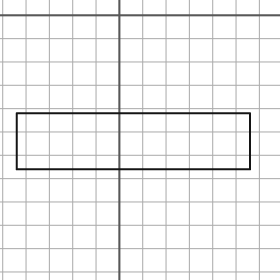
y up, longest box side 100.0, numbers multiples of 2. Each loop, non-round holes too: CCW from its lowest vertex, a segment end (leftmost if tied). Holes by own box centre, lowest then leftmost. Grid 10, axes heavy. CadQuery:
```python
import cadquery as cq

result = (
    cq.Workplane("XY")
    .moveTo(-44.0, -66.0)
    .lineTo(56.0, -66.0)
    .lineTo(56.0, -42.0)
    .lineTo(-44.0, -42.0)
    .close()
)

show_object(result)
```